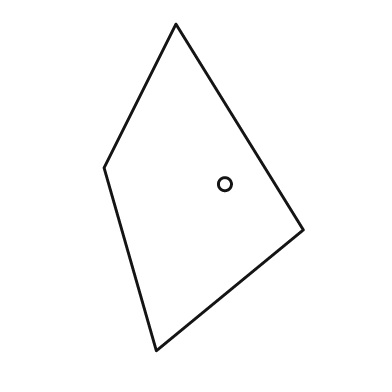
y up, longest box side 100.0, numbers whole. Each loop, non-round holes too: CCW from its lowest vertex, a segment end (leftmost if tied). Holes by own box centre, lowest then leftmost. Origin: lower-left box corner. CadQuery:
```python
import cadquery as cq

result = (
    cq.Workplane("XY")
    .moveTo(16.0, 0.0)
    .lineTo(61.0, 37.0)
    .lineTo(22.0, 100.0)
    .lineTo(0.0, 56.0)
    .close()
    .moveTo(37.0, 51.0)
    .circle(2.0)
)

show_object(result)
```